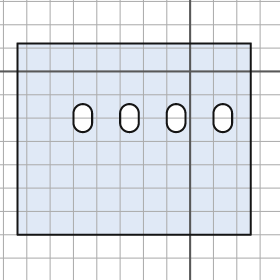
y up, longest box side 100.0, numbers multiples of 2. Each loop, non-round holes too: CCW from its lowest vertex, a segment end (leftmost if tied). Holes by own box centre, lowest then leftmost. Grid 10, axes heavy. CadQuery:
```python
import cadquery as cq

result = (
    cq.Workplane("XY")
    .moveTo(-74.0, -70.0)
    .lineTo(26.0, -70.0)
    .lineTo(26.0, 12.0)
    .lineTo(-74.0, 12.0)
    .close()
    .moveTo(-50.0, -22.0)
    .threePointArc((-46.0, -26.0), (-42.0, -22.0))
    .lineTo(-42.0, -18.0)
    .threePointArc((-46.0, -14.0), (-50.0, -18.0))
    .close()
    .moveTo(-30.0, -22.0)
    .threePointArc((-26.0, -26.0), (-22.0, -22.0))
    .lineTo(-22.0, -18.0)
    .threePointArc((-26.0, -14.0), (-30.0, -18.0))
    .close()
    .moveTo(-10.0, -22.0)
    .threePointArc((-6.0, -26.0), (-2.0, -22.0))
    .lineTo(-2.0, -18.0)
    .threePointArc((-6.0, -14.0), (-10.0, -18.0))
    .close()
    .moveTo(10.0, -22.0)
    .threePointArc((14.0, -26.0), (18.0, -22.0))
    .lineTo(18.0, -18.0)
    .threePointArc((14.0, -14.0), (10.0, -18.0))
    .close()
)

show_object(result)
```